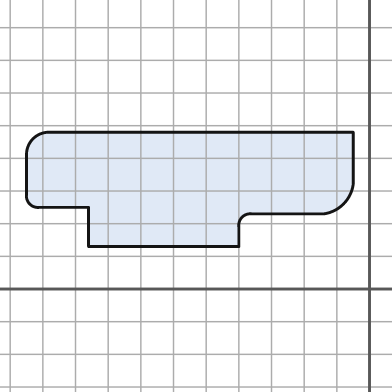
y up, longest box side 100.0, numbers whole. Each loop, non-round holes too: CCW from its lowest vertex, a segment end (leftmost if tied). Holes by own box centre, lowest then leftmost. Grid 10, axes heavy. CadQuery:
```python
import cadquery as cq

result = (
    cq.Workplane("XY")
    .moveTo(-86.0, 13.0)
    .lineTo(-40.0, 13.0)
    .lineTo(-40.0, 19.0)
    .threePointArc((-39.0, 22.0), (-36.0, 23.0))
    .lineTo(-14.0, 23.0)
    .threePointArc((-8.0, 26.0), (-5.0, 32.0))
    .lineTo(-5.0, 48.0)
    .lineTo(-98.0, 48.0)
    .threePointArc((-103.0, 46.0), (-105.0, 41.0))
    .lineTo(-105.0, 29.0)
    .threePointArc((-104.0, 26.0), (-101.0, 25.0))
    .lineTo(-86.0, 25.0)
    .close()
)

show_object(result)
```